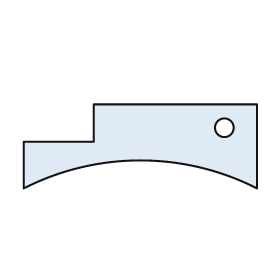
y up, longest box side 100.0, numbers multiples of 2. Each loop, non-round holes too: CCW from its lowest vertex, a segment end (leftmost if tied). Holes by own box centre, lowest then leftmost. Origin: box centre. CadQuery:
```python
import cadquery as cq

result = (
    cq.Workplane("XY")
    .moveTo(-50.0, -18.0)
    .threePointArc((0.0, -6.0), (50.0, -18.0))
    .lineTo(50.0, 18.0)
    .lineTo(-20.0, 18.0)
    .lineTo(-20.0, 2.0)
    .lineTo(-50.0, 2.0)
    .close()
    .moveTo(36.0, 8.0)
    .circle(4.0)
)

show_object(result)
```